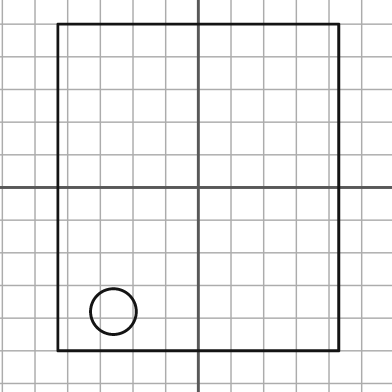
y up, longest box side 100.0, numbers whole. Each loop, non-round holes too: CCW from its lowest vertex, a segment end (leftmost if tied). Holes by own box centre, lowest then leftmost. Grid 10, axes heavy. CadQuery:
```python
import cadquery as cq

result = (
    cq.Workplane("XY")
    .moveTo(-43.0, -50.0)
    .lineTo(43.0, -50.0)
    .lineTo(43.0, 50.0)
    .lineTo(-43.0, 50.0)
    .close()
    .moveTo(-26.0, -38.0)
    .circle(7.0)
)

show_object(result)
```